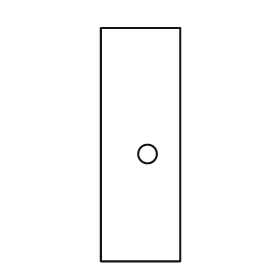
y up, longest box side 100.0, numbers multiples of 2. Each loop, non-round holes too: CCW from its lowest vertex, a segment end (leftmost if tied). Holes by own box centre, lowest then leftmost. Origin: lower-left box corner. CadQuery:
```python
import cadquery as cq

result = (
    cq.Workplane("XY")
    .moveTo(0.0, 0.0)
    .lineTo(34.0, 0.0)
    .lineTo(34.0, 100.0)
    .lineTo(0.0, 100.0)
    .close()
    .moveTo(20.0, 46.0)
    .circle(4.0)
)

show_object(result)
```